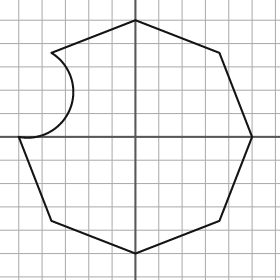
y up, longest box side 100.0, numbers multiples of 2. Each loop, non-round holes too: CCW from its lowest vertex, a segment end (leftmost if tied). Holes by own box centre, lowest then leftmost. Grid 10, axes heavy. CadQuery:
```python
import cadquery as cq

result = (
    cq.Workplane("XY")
    .moveTo(0.0, -50.0)
    .lineTo(36.0, -36.0)
    .lineTo(50.0, 0.0)
    .lineTo(36.0, 36.0)
    .lineTo(0.0, 50.0)
    .lineTo(-36.0, 36.0)
    .threePointArc((-28.0, 12.0), (-50.0, 0.0))
    .lineTo(-36.0, -36.0)
    .close()
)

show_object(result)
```